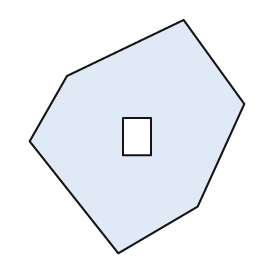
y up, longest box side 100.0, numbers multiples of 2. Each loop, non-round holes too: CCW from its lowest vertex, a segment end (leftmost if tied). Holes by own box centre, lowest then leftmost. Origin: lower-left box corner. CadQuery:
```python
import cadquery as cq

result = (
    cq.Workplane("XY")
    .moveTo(38.0, 0.0)
    .lineTo(72.0, 20.0)
    .lineTo(92.0, 64.0)
    .lineTo(66.0, 100.0)
    .lineTo(16.0, 76.0)
    .lineTo(0.0, 48.0)
    .close()
    .moveTo(40.0, 42.0)
    .lineTo(52.0, 42.0)
    .lineTo(52.0, 58.0)
    .lineTo(40.0, 58.0)
    .close()
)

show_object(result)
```